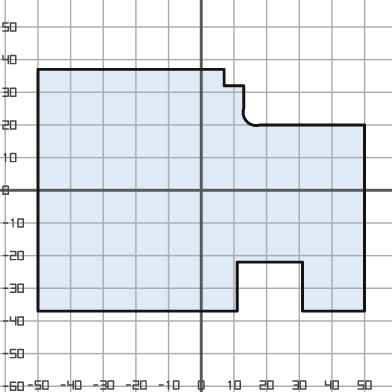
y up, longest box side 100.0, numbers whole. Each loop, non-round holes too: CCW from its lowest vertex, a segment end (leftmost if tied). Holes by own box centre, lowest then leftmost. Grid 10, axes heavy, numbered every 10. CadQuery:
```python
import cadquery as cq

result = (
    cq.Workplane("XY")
    .moveTo(-50.0, -37.0)
    .lineTo(11.0, -37.0)
    .lineTo(11.0, -22.0)
    .lineTo(31.0, -22.0)
    .lineTo(31.0, -37.0)
    .lineTo(50.0, -37.0)
    .lineTo(50.0, 20.0)
    .lineTo(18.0, 20.0)
    .threePointArc((14.0, 21.0), (13.0, 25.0))
    .lineTo(13.0, 32.0)
    .lineTo(7.0, 32.0)
    .lineTo(7.0, 37.0)
    .lineTo(-50.0, 37.0)
    .close()
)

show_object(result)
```